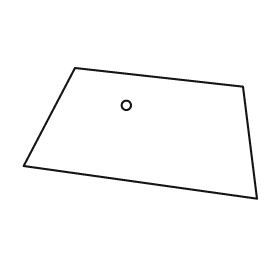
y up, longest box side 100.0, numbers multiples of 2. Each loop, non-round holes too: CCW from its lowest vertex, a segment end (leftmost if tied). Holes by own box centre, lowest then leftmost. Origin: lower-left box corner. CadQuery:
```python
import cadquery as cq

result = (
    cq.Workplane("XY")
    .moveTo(100.0, 0.0)
    .lineTo(94.0, 48.0)
    .lineTo(22.0, 56.0)
    .lineTo(0.0, 14.0)
    .close()
    .moveTo(44.0, 40.0)
    .circle(2.0)
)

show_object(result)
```